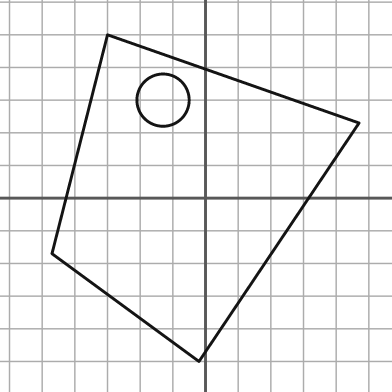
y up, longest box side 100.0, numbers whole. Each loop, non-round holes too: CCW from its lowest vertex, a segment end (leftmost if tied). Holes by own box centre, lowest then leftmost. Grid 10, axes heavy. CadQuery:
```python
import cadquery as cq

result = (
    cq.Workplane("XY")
    .moveTo(-2.0, -50.0)
    .lineTo(47.0, 23.0)
    .lineTo(-30.0, 50.0)
    .lineTo(-47.0, -17.0)
    .close()
    .moveTo(-13.0, 30.0)
    .circle(8.0)
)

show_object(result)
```